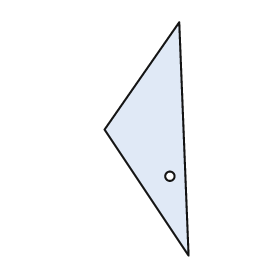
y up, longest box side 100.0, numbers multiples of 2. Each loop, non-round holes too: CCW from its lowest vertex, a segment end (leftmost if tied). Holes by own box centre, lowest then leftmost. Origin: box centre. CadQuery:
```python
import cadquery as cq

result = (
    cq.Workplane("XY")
    .moveTo(18.0, -50.0)
    .lineTo(14.0, 50.0)
    .lineTo(-18.0, 4.0)
    .close()
    .moveTo(10.0, -16.0)
    .circle(2.0)
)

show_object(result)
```